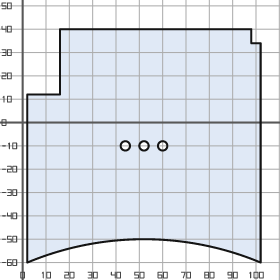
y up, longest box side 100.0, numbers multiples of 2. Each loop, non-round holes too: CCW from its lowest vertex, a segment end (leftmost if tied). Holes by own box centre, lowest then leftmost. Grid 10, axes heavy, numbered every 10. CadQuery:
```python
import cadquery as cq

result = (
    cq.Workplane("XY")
    .moveTo(2.0, -60.0)
    .threePointArc((52.0, -50.0), (102.0, -60.0))
    .lineTo(102.0, 34.0)
    .lineTo(98.0, 34.0)
    .lineTo(98.0, 40.0)
    .lineTo(16.0, 40.0)
    .lineTo(16.0, 12.0)
    .lineTo(2.0, 12.0)
    .close()
    .moveTo(44.0, -10.0)
    .circle(2.0)
    .moveTo(52.0, -10.0)
    .circle(2.0)
    .moveTo(60.0, -10.0)
    .circle(2.0)
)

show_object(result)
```